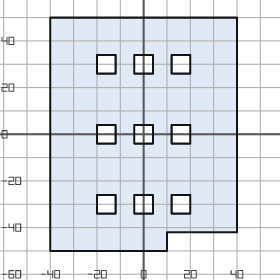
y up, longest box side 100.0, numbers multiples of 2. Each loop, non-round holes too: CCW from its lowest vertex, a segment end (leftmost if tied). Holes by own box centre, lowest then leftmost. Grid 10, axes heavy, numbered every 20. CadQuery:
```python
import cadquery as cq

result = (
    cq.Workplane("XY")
    .moveTo(-40.0, -50.0)
    .lineTo(10.0, -50.0)
    .lineTo(10.0, -42.0)
    .lineTo(40.0, -42.0)
    .lineTo(40.0, 50.0)
    .lineTo(-40.0, 50.0)
    .close()
    .moveTo(-20.0, -34.0)
    .lineTo(-12.0, -34.0)
    .lineTo(-12.0, -26.0)
    .lineTo(-20.0, -26.0)
    .close()
    .moveTo(-4.0, -34.0)
    .lineTo(4.0, -34.0)
    .lineTo(4.0, -26.0)
    .lineTo(-4.0, -26.0)
    .close()
    .moveTo(12.0, -34.0)
    .lineTo(20.0, -34.0)
    .lineTo(20.0, -26.0)
    .lineTo(12.0, -26.0)
    .close()
    .moveTo(-20.0, -4.0)
    .lineTo(-12.0, -4.0)
    .lineTo(-12.0, 4.0)
    .lineTo(-20.0, 4.0)
    .close()
    .moveTo(-4.0, -4.0)
    .lineTo(4.0, -4.0)
    .lineTo(4.0, 4.0)
    .lineTo(-4.0, 4.0)
    .close()
    .moveTo(12.0, -4.0)
    .lineTo(20.0, -4.0)
    .lineTo(20.0, 4.0)
    .lineTo(12.0, 4.0)
    .close()
    .moveTo(-20.0, 26.0)
    .lineTo(-12.0, 26.0)
    .lineTo(-12.0, 34.0)
    .lineTo(-20.0, 34.0)
    .close()
    .moveTo(-4.0, 26.0)
    .lineTo(4.0, 26.0)
    .lineTo(4.0, 34.0)
    .lineTo(-4.0, 34.0)
    .close()
    .moveTo(12.0, 26.0)
    .lineTo(20.0, 26.0)
    .lineTo(20.0, 34.0)
    .lineTo(12.0, 34.0)
    .close()
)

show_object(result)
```